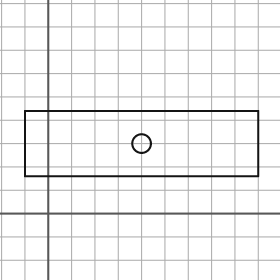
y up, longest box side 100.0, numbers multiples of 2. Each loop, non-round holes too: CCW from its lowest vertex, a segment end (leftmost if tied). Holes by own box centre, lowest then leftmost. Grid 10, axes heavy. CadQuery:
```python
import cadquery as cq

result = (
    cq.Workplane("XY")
    .moveTo(-10.0, 16.0)
    .lineTo(90.0, 16.0)
    .lineTo(90.0, 44.0)
    .lineTo(-10.0, 44.0)
    .close()
    .moveTo(40.0, 30.0)
    .circle(4.0)
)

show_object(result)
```